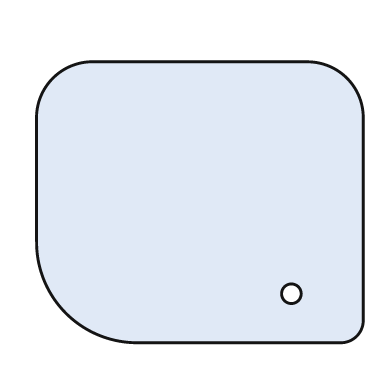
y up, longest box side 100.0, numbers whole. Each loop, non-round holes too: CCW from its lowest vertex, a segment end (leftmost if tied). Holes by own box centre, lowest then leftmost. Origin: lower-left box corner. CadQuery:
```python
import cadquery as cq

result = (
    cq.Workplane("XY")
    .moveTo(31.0, 0.0)
    .lineTo(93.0, 0.0)
    .threePointArc((98.0, 2.0), (100.0, 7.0))
    .lineTo(100.0, 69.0)
    .threePointArc((95.0, 81.0), (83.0, 86.0))
    .lineTo(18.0, 86.0)
    .threePointArc((5.0, 81.0), (0.0, 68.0))
    .lineTo(0.0, 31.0)
    .threePointArc((9.0, 9.0), (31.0, 0.0))
    .close()
    .moveTo(78.0, 15.0)
    .circle(3.0)
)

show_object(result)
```